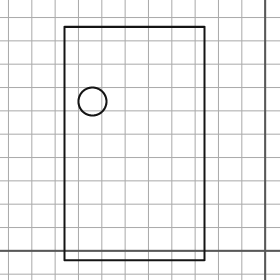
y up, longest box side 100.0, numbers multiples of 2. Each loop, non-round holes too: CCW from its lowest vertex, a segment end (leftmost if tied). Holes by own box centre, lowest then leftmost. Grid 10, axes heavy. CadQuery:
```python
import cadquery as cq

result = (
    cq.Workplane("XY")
    .moveTo(-86.0, -4.0)
    .lineTo(-26.0, -4.0)
    .lineTo(-26.0, 96.0)
    .lineTo(-86.0, 96.0)
    .close()
    .moveTo(-74.0, 64.0)
    .circle(6.0)
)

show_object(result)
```